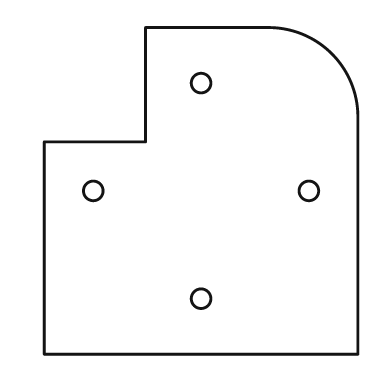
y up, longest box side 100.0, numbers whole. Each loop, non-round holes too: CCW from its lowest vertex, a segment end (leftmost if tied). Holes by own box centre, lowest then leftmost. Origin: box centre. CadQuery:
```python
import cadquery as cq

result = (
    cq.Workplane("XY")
    .moveTo(-48.0, -50.0)
    .lineTo(48.0, -50.0)
    .lineTo(48.0, 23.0)
    .threePointArc((40.0, 42.0), (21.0, 50.0))
    .lineTo(-17.0, 50.0)
    .lineTo(-17.0, 15.0)
    .lineTo(-48.0, 15.0)
    .close()
    .moveTo(0.0, -33.0)
    .circle(3.0)
    .moveTo(-33.0, 0.0)
    .circle(3.0)
    .moveTo(33.0, 0.0)
    .circle(3.0)
    .moveTo(0.0, 33.0)
    .circle(3.0)
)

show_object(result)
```